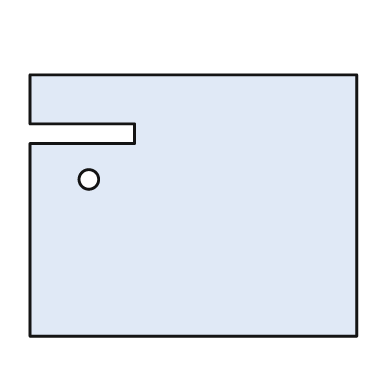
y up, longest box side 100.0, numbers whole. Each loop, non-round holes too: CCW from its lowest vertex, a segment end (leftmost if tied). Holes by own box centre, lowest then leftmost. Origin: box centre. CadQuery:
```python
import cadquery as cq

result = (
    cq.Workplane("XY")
    .moveTo(-50.0, -40.0)
    .lineTo(50.0, -40.0)
    .lineTo(50.0, 40.0)
    .lineTo(-50.0, 40.0)
    .lineTo(-50.0, 25.0)
    .lineTo(-18.0, 25.0)
    .lineTo(-18.0, 19.0)
    .lineTo(-50.0, 19.0)
    .close()
    .moveTo(-32.0, 8.0)
    .circle(3.0)
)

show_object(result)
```